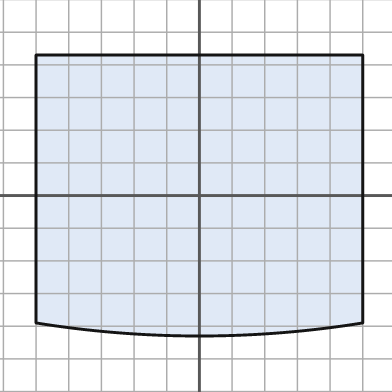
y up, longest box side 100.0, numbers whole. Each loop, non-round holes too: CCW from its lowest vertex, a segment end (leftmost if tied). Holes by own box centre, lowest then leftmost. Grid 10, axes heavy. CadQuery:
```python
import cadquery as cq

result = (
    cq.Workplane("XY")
    .moveTo(-50.0, -39.0)
    .threePointArc((0.0, -43.0), (50.0, -39.0))
    .lineTo(50.0, 43.0)
    .lineTo(-50.0, 43.0)
    .close()
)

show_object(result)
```